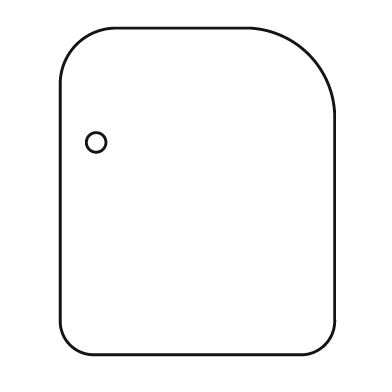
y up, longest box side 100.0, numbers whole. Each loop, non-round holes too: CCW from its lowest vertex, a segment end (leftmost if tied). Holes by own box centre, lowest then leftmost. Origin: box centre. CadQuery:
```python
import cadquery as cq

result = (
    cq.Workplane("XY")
    .moveTo(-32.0, -50.0)
    .lineTo(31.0, -50.0)
    .threePointArc((39.0, -47.0), (42.0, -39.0))
    .lineTo(42.0, 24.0)
    .threePointArc((34.0, 42.0), (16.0, 50.0))
    .lineTo(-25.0, 50.0)
    .threePointArc((-37.0, 45.0), (-42.0, 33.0))
    .lineTo(-42.0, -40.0)
    .threePointArc((-39.0, -47.0), (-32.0, -50.0))
    .close()
    .moveTo(-31.0, 15.0)
    .circle(3.0)
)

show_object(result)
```